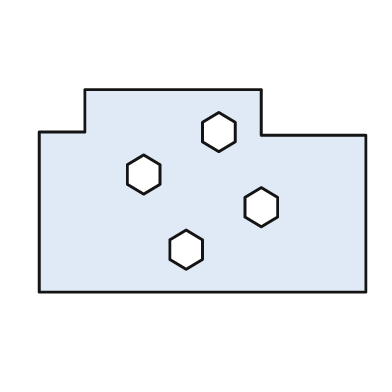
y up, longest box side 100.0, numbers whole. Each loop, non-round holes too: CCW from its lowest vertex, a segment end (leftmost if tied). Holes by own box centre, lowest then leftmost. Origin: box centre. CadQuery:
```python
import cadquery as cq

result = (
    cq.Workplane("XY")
    .moveTo(-50.0, -31.0)
    .lineTo(50.0, -31.0)
    .lineTo(50.0, 17.0)
    .lineTo(18.0, 17.0)
    .lineTo(18.0, 31.0)
    .lineTo(-36.0, 31.0)
    .lineTo(-36.0, 18.0)
    .lineTo(-50.0, 18.0)
    .close()
    .moveTo(-5.0, -24.0)
    .lineTo(0.0, -21.0)
    .lineTo(0.0, -15.0)
    .lineTo(-5.0, -12.0)
    .lineTo(-10.0, -15.0)
    .lineTo(-10.0, -21.0)
    .close()
    .moveTo(18.0, -11.0)
    .lineTo(23.0, -8.0)
    .lineTo(23.0, -2.0)
    .lineTo(18.0, 1.0)
    .lineTo(13.0, -2.0)
    .lineTo(13.0, -8.0)
    .close()
    .moveTo(-18.0, -1.0)
    .lineTo(-13.0, 2.0)
    .lineTo(-13.0, 8.0)
    .lineTo(-18.0, 11.0)
    .lineTo(-23.0, 8.0)
    .lineTo(-23.0, 2.0)
    .close()
    .moveTo(5.0, 12.0)
    .lineTo(10.0, 15.0)
    .lineTo(10.0, 21.0)
    .lineTo(5.0, 24.0)
    .lineTo(0.0, 21.0)
    .lineTo(0.0, 15.0)
    .close()
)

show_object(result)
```